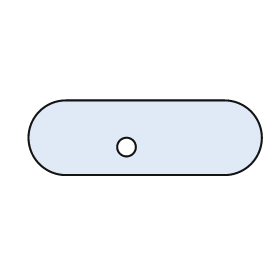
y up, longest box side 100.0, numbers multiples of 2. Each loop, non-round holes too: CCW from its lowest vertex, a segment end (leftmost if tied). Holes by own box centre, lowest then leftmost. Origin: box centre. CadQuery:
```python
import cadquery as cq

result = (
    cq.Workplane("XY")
    .moveTo(-34.0, -16.0)
    .lineTo(34.0, -16.0)
    .threePointArc((50.0, 0.0), (34.0, 16.0))
    .lineTo(-34.0, 16.0)
    .threePointArc((-50.0, 0.0), (-34.0, -16.0))
    .close()
    .moveTo(-8.0, -4.0)
    .circle(4.0)
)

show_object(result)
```